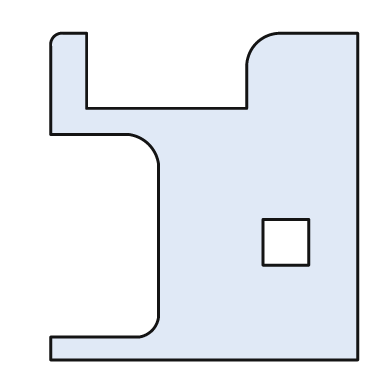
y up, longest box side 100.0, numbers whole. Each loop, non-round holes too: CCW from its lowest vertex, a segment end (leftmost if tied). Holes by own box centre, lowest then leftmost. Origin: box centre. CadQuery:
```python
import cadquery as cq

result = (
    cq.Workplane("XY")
    .moveTo(-47.0, -50.0)
    .lineTo(47.0, -50.0)
    .lineTo(47.0, 50.0)
    .lineTo(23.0, 50.0)
    .threePointArc((16.0, 47.0), (13.0, 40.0))
    .lineTo(13.0, 27.0)
    .lineTo(-36.0, 27.0)
    .lineTo(-36.0, 50.0)
    .lineTo(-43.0, 50.0)
    .threePointArc((-46.0, 49.0), (-47.0, 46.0))
    .lineTo(-47.0, 19.0)
    .lineTo(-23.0, 19.0)
    .threePointArc((-17.0, 16.0), (-14.0, 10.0))
    .lineTo(-14.0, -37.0)
    .threePointArc((-16.0, -41.0), (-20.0, -43.0))
    .lineTo(-47.0, -43.0)
    .close()
    .moveTo(18.0, -21.0)
    .lineTo(32.0, -21.0)
    .lineTo(32.0, -7.0)
    .lineTo(18.0, -7.0)
    .close()
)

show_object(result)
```